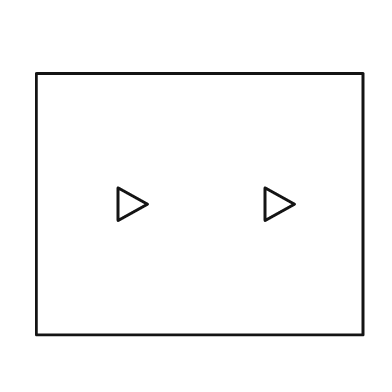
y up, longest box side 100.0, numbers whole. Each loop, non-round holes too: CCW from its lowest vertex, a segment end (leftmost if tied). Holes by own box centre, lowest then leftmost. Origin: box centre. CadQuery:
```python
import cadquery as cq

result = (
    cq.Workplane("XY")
    .moveTo(-50.0, -40.0)
    .lineTo(50.0, -40.0)
    .lineTo(50.0, 40.0)
    .lineTo(-50.0, 40.0)
    .close()
    .moveTo(-25.0, -5.0)
    .lineTo(-16.0, 0.0)
    .lineTo(-25.0, 5.0)
    .close()
    .moveTo(20.0, -5.0)
    .lineTo(29.0, 0.0)
    .lineTo(20.0, 5.0)
    .close()
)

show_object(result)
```